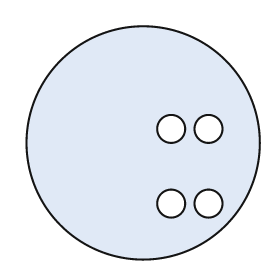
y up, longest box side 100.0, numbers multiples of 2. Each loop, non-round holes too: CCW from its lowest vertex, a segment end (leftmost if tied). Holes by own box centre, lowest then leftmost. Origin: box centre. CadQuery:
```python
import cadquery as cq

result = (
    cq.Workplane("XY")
    .moveTo(0.0, 0.0)
    .circle(50.0)
    .moveTo(12.0, -26.0)
    .circle(6.0)
    .moveTo(28.0, -26.0)
    .circle(6.0)
    .moveTo(12.0, 6.0)
    .circle(6.0)
    .moveTo(28.0, 6.0)
    .circle(6.0)
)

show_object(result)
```